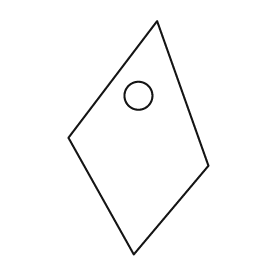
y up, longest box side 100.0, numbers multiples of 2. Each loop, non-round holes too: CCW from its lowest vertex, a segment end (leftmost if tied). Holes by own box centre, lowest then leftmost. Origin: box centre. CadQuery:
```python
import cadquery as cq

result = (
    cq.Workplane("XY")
    .moveTo(-2.0, -50.0)
    .lineTo(30.0, -12.0)
    .lineTo(8.0, 50.0)
    .lineTo(-30.0, 0.0)
    .close()
    .moveTo(0.0, 18.0)
    .circle(6.0)
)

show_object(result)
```